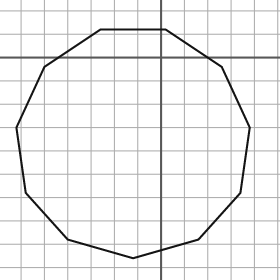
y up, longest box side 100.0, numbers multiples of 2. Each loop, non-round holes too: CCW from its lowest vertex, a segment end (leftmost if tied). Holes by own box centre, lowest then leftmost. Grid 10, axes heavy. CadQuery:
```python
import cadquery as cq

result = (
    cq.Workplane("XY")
    .moveTo(-12.0, -86.0)
    .lineTo(16.0, -78.0)
    .lineTo(34.0, -58.0)
    .lineTo(38.0, -30.0)
    .lineTo(26.0, -4.0)
    .lineTo(2.0, 12.0)
    .lineTo(-26.0, 12.0)
    .lineTo(-50.0, -4.0)
    .lineTo(-62.0, -30.0)
    .lineTo(-58.0, -58.0)
    .lineTo(-40.0, -78.0)
    .close()
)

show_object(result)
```